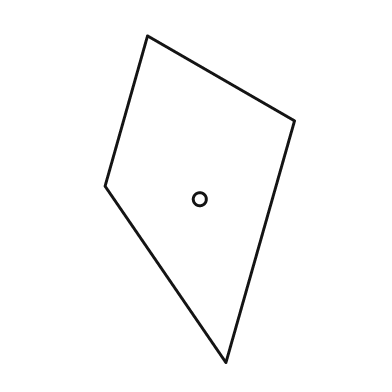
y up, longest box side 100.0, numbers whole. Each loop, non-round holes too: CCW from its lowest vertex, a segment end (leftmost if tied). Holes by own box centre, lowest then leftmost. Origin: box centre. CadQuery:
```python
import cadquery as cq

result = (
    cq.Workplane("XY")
    .moveTo(8.0, -50.0)
    .lineTo(29.0, 24.0)
    .lineTo(-16.0, 50.0)
    .lineTo(-29.0, 4.0)
    .close()
    .moveTo(0.0, 0.0)
    .circle(2.0)
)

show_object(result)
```